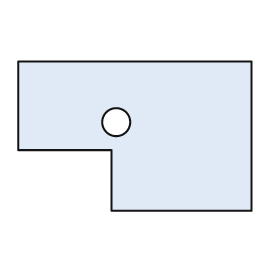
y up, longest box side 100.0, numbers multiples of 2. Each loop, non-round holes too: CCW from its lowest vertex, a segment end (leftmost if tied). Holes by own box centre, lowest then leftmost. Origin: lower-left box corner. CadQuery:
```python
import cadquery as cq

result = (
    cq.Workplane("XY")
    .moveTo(40.0, 0.0)
    .lineTo(100.0, 0.0)
    .lineTo(100.0, 64.0)
    .lineTo(0.0, 64.0)
    .lineTo(0.0, 26.0)
    .lineTo(40.0, 26.0)
    .close()
    .moveTo(42.0, 38.0)
    .circle(6.0)
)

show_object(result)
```